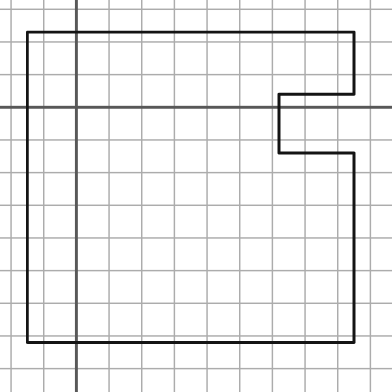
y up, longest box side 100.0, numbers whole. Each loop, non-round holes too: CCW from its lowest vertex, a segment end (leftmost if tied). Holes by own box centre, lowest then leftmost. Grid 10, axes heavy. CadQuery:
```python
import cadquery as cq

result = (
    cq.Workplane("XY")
    .moveTo(-15.0, -72.0)
    .lineTo(85.0, -72.0)
    .lineTo(85.0, -14.0)
    .lineTo(62.0, -14.0)
    .lineTo(62.0, 4.0)
    .lineTo(85.0, 4.0)
    .lineTo(85.0, 23.0)
    .lineTo(-15.0, 23.0)
    .close()
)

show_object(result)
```